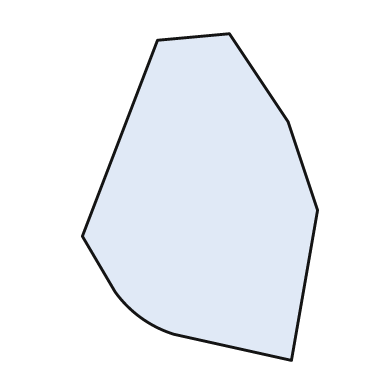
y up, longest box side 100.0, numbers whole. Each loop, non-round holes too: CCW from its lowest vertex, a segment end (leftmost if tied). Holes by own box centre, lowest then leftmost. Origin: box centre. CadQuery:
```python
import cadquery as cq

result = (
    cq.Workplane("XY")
    .moveTo(28.0, -50.0)
    .lineTo(36.0, -4.0)
    .lineTo(27.0, 23.0)
    .lineTo(9.0, 50.0)
    .lineTo(-13.0, 48.0)
    .lineTo(-36.0, -12.0)
    .lineTo(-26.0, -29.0)
    .threePointArc((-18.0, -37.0), (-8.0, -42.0))
    .close()
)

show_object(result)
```